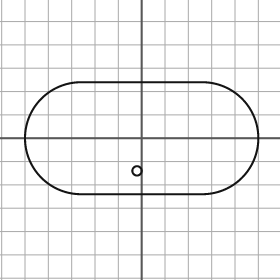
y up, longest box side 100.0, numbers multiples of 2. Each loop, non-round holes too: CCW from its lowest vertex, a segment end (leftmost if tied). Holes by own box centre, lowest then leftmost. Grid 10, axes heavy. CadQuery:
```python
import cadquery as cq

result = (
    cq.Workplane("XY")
    .moveTo(-26.0, -24.0)
    .lineTo(26.0, -24.0)
    .threePointArc((50.0, 0.0), (26.0, 24.0))
    .lineTo(-26.0, 24.0)
    .threePointArc((-50.0, 0.0), (-26.0, -24.0))
    .close()
    .moveTo(-2.0, -14.0)
    .circle(2.0)
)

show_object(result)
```